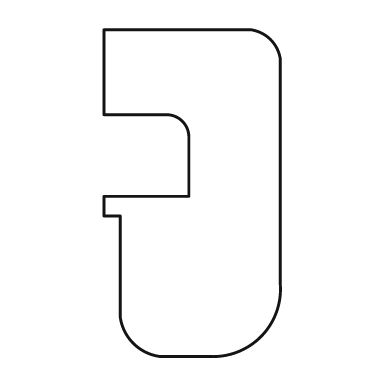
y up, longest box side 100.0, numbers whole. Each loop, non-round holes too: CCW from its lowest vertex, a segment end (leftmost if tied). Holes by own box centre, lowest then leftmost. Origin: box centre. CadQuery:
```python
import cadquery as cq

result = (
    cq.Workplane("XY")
    .moveTo(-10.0, -50.0)
    .lineTo(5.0, -50.0)
    .threePointArc((21.0, -44.0), (27.0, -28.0))
    .lineTo(27.0, 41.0)
    .threePointArc((24.0, 47.0), (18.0, 50.0))
    .lineTo(-27.0, 50.0)
    .lineTo(-27.0, 24.0)
    .lineTo(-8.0, 24.0)
    .threePointArc((-3.0, 22.0), (-1.0, 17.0))
    .lineTo(-1.0, -1.0)
    .lineTo(-27.0, -1.0)
    .lineTo(-27.0, -7.0)
    .lineTo(-22.0, -7.0)
    .lineTo(-22.0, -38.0)
    .threePointArc((-18.0, -46.0), (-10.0, -50.0))
    .close()
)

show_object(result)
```